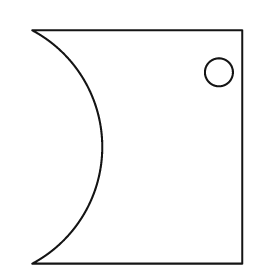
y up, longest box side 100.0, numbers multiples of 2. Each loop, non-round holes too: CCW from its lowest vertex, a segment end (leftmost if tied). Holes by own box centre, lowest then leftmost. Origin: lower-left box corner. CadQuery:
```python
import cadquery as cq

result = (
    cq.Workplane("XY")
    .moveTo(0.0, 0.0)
    .lineTo(90.0, 0.0)
    .lineTo(90.0, 100.0)
    .lineTo(0.0, 100.0)
    .threePointArc((30.0, 50.0), (0.0, 0.0))
    .close()
    .moveTo(80.0, 82.0)
    .circle(6.0)
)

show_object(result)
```